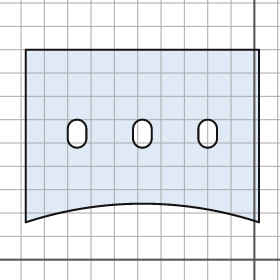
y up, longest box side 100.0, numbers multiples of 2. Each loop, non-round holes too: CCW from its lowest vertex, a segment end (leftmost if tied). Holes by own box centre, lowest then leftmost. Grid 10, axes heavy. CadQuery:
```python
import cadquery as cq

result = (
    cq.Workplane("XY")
    .moveTo(-98.0, 16.0)
    .threePointArc((-48.0, 24.0), (2.0, 16.0))
    .lineTo(2.0, 90.0)
    .lineTo(-98.0, 90.0)
    .close()
    .moveTo(-80.0, 52.0)
    .threePointArc((-76.0, 48.0), (-72.0, 52.0))
    .lineTo(-72.0, 56.0)
    .threePointArc((-76.0, 60.0), (-80.0, 56.0))
    .close()
    .moveTo(-52.0, 52.0)
    .threePointArc((-48.0, 48.0), (-44.0, 52.0))
    .lineTo(-44.0, 56.0)
    .threePointArc((-48.0, 60.0), (-52.0, 56.0))
    .close()
    .moveTo(-24.0, 52.0)
    .threePointArc((-20.0, 48.0), (-16.0, 52.0))
    .lineTo(-16.0, 56.0)
    .threePointArc((-20.0, 60.0), (-24.0, 56.0))
    .close()
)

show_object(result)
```